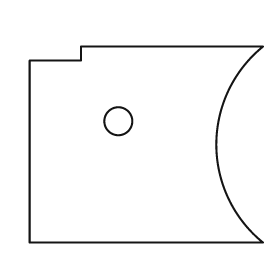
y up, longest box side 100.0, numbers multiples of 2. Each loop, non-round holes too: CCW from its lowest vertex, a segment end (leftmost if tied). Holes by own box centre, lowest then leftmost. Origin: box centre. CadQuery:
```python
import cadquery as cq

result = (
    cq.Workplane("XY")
    .moveTo(-50.0, -42.0)
    .lineTo(50.0, -42.0)
    .threePointArc((30.0, 0.0), (50.0, 42.0))
    .lineTo(-28.0, 42.0)
    .lineTo(-28.0, 36.0)
    .lineTo(-50.0, 36.0)
    .close()
    .moveTo(-12.0, 10.0)
    .circle(6.0)
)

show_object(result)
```